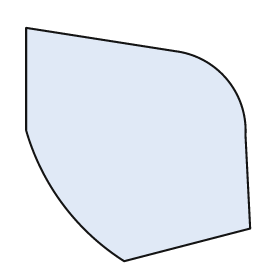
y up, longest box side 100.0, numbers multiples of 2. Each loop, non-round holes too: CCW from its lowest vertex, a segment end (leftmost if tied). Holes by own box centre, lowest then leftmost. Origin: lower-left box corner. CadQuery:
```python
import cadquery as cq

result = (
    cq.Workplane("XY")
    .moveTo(42.0, 0.0)
    .lineTo(96.0, 14.0)
    .lineTo(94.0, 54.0)
    .threePointArc((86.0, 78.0), (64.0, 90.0))
    .lineTo(0.0, 100.0)
    .lineTo(0.0, 56.0)
    .threePointArc((16.0, 24.0), (42.0, 0.0))
    .close()
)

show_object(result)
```